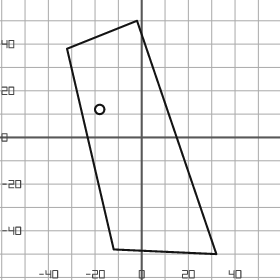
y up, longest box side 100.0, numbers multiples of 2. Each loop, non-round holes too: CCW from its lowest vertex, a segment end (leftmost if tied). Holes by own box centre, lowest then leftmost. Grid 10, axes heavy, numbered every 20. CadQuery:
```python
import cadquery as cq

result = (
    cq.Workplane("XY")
    .moveTo(32.0, -50.0)
    .lineTo(-2.0, 50.0)
    .lineTo(-32.0, 38.0)
    .lineTo(-12.0, -48.0)
    .close()
    .moveTo(-18.0, 12.0)
    .circle(2.0)
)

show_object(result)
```